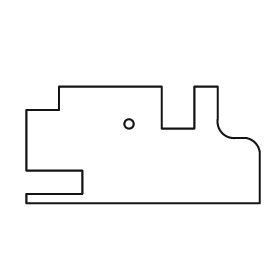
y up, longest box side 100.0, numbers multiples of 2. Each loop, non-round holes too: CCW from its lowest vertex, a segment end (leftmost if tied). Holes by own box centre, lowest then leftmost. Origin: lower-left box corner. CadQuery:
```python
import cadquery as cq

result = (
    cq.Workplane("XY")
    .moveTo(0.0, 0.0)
    .lineTo(100.0, 0.0)
    .lineTo(100.0, 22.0)
    .threePointArc((98.0, 26.0), (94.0, 28.0))
    .lineTo(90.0, 28.0)
    .threePointArc((84.0, 30.0), (82.0, 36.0))
    .lineTo(82.0, 50.0)
    .lineTo(72.0, 50.0)
    .lineTo(72.0, 32.0)
    .lineTo(58.0, 32.0)
    .lineTo(58.0, 50.0)
    .lineTo(14.0, 50.0)
    .lineTo(14.0, 40.0)
    .lineTo(0.0, 40.0)
    .lineTo(0.0, 14.0)
    .lineTo(24.0, 14.0)
    .lineTo(24.0, 4.0)
    .lineTo(0.0, 4.0)
    .close()
    .moveTo(44.0, 34.0)
    .circle(2.0)
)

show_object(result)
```